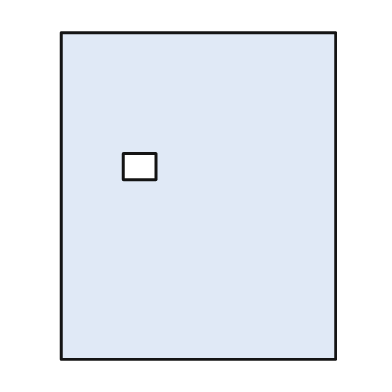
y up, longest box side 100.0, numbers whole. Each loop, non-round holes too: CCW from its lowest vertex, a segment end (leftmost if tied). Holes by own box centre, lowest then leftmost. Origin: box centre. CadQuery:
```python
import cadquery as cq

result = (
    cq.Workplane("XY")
    .moveTo(-42.0, -50.0)
    .lineTo(42.0, -50.0)
    .lineTo(42.0, 50.0)
    .lineTo(-42.0, 50.0)
    .close()
    .moveTo(-23.0, 5.0)
    .lineTo(-13.0, 5.0)
    .lineTo(-13.0, 13.0)
    .lineTo(-23.0, 13.0)
    .close()
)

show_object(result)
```